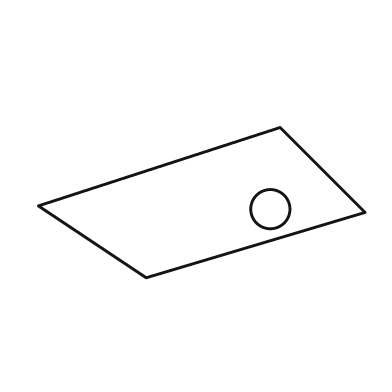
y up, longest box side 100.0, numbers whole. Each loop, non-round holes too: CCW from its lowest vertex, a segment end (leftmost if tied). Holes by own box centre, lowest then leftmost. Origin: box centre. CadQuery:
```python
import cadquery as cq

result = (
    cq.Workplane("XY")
    .moveTo(-17.0, -23.0)
    .lineTo(50.0, -3.0)
    .lineTo(24.0, 23.0)
    .lineTo(-50.0, -1.0)
    .close()
    .moveTo(21.0, -2.0)
    .circle(6.0)
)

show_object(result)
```